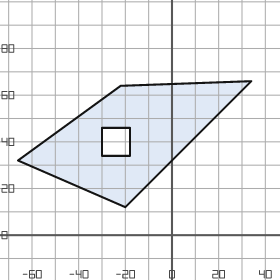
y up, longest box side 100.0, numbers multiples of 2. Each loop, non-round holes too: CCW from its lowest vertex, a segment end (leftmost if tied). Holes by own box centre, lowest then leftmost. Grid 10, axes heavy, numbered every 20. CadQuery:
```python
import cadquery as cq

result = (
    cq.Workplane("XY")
    .moveTo(-20.0, 12.0)
    .lineTo(34.0, 66.0)
    .lineTo(-22.0, 64.0)
    .lineTo(-66.0, 32.0)
    .close()
    .moveTo(-30.0, 34.0)
    .lineTo(-18.0, 34.0)
    .lineTo(-18.0, 46.0)
    .lineTo(-30.0, 46.0)
    .close()
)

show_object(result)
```